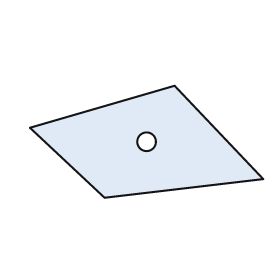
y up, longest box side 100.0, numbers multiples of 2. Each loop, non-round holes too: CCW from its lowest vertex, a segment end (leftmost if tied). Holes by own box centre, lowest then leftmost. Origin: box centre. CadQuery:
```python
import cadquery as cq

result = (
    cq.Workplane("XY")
    .moveTo(-18.0, -24.0)
    .lineTo(50.0, -16.0)
    .lineTo(12.0, 24.0)
    .lineTo(-50.0, 6.0)
    .close()
    .moveTo(0.0, 0.0)
    .circle(4.0)
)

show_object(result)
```